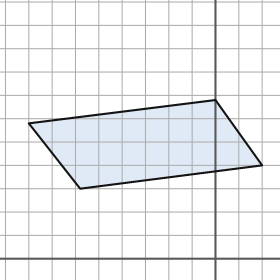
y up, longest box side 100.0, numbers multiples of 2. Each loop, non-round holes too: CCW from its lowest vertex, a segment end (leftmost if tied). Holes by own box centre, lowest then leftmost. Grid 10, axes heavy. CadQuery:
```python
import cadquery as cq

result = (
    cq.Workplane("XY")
    .moveTo(-58.0, 30.0)
    .lineTo(20.0, 40.0)
    .lineTo(0.0, 68.0)
    .lineTo(-80.0, 58.0)
    .close()
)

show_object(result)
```